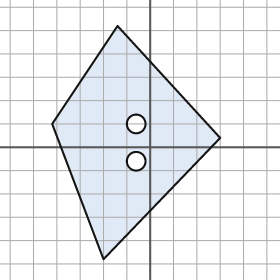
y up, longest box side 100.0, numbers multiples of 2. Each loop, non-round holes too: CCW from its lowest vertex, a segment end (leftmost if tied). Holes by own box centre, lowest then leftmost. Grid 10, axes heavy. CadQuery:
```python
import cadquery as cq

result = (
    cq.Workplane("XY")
    .moveTo(-20.0, -48.0)
    .lineTo(30.0, 4.0)
    .lineTo(-14.0, 52.0)
    .lineTo(-42.0, 10.0)
    .close()
    .moveTo(-6.0, -6.0)
    .circle(4.0)
    .moveTo(-6.0, 10.0)
    .circle(4.0)
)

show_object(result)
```